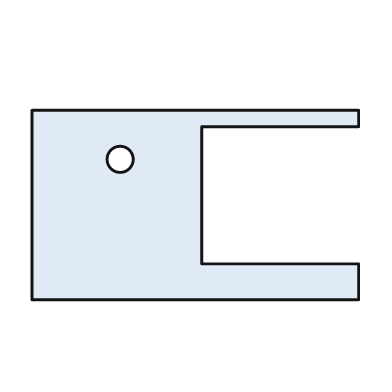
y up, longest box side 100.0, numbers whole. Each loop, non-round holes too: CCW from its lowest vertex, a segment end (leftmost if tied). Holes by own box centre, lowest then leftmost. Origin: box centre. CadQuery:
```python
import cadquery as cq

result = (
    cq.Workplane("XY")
    .moveTo(-50.0, -29.0)
    .lineTo(50.0, -29.0)
    .lineTo(50.0, -18.0)
    .lineTo(2.0, -18.0)
    .lineTo(2.0, 24.0)
    .lineTo(50.0, 24.0)
    .lineTo(50.0, 29.0)
    .lineTo(-50.0, 29.0)
    .close()
    .moveTo(-23.0, 14.0)
    .circle(4.0)
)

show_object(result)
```